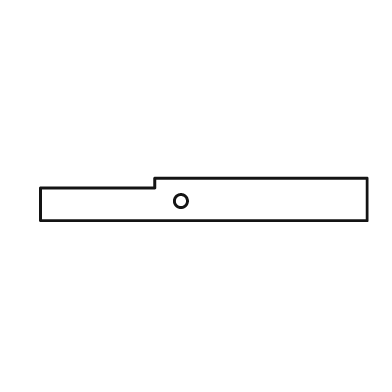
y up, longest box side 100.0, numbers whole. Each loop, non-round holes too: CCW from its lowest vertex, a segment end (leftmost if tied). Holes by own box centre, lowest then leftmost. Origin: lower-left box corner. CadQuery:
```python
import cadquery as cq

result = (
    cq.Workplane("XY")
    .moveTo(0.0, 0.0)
    .lineTo(100.0, 0.0)
    .lineTo(100.0, 13.0)
    .lineTo(35.0, 13.0)
    .lineTo(35.0, 10.0)
    .lineTo(0.0, 10.0)
    .close()
    .moveTo(43.0, 6.0)
    .circle(2.0)
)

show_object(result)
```